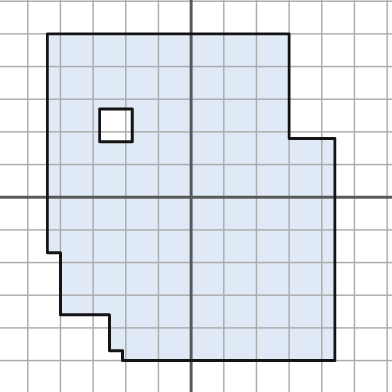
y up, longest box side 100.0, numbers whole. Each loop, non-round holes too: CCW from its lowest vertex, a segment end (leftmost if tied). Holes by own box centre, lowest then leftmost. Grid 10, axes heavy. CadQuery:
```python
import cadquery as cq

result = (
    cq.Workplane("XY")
    .moveTo(-21.0, -50.0)
    .lineTo(44.0, -50.0)
    .lineTo(44.0, 18.0)
    .lineTo(30.0, 18.0)
    .lineTo(30.0, 50.0)
    .lineTo(-44.0, 50.0)
    .lineTo(-44.0, -17.0)
    .lineTo(-40.0, -17.0)
    .lineTo(-40.0, -36.0)
    .lineTo(-25.0, -36.0)
    .lineTo(-25.0, -47.0)
    .lineTo(-21.0, -47.0)
    .close()
    .moveTo(-28.0, 17.0)
    .lineTo(-18.0, 17.0)
    .lineTo(-18.0, 27.0)
    .lineTo(-28.0, 27.0)
    .close()
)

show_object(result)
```